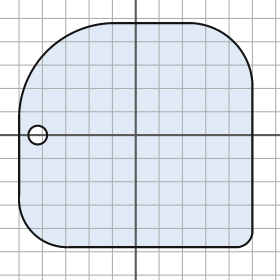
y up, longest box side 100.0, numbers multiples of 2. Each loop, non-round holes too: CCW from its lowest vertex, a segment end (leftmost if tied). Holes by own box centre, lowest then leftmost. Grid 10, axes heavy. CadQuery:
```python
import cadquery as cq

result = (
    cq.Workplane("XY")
    .moveTo(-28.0, -48.0)
    .lineTo(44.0, -48.0)
    .threePointArc((48.0, -46.0), (50.0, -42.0))
    .lineTo(50.0, 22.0)
    .threePointArc((42.0, 40.0), (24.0, 48.0))
    .lineTo(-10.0, 48.0)
    .threePointArc((-38.0, 36.0), (-50.0, 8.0))
    .lineTo(-50.0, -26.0)
    .threePointArc((-44.0, -42.0), (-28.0, -48.0))
    .close()
    .moveTo(-42.0, 0.0)
    .circle(4.0)
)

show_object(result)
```